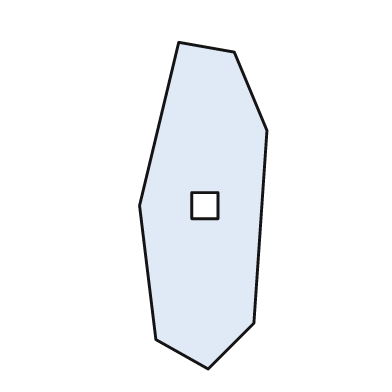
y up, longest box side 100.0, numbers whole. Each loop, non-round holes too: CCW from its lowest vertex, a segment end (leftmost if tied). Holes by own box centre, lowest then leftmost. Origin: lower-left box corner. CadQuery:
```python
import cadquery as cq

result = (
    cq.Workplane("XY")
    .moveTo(21.0, 0.0)
    .lineTo(35.0, 14.0)
    .lineTo(39.0, 73.0)
    .lineTo(29.0, 97.0)
    .lineTo(12.0, 100.0)
    .lineTo(0.0, 50.0)
    .lineTo(5.0, 9.0)
    .close()
    .moveTo(16.0, 46.0)
    .lineTo(24.0, 46.0)
    .lineTo(24.0, 54.0)
    .lineTo(16.0, 54.0)
    .close()
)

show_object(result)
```